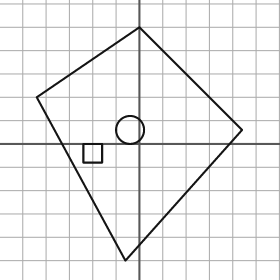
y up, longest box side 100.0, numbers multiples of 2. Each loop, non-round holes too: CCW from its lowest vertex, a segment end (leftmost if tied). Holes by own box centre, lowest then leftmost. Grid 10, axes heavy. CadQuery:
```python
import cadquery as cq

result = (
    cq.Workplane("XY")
    .moveTo(-6.0, -50.0)
    .lineTo(44.0, 6.0)
    .lineTo(0.0, 50.0)
    .lineTo(-44.0, 20.0)
    .close()
    .moveTo(-24.0, -8.0)
    .lineTo(-16.0, -8.0)
    .lineTo(-16.0, 0.0)
    .lineTo(-24.0, 0.0)
    .close()
    .moveTo(-4.0, 6.0)
    .circle(6.0)
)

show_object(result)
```